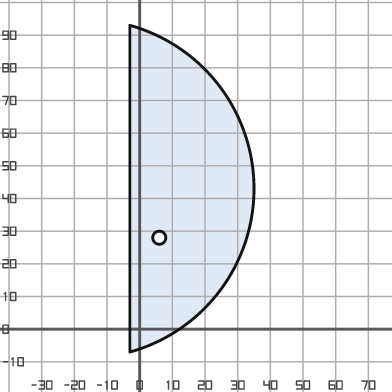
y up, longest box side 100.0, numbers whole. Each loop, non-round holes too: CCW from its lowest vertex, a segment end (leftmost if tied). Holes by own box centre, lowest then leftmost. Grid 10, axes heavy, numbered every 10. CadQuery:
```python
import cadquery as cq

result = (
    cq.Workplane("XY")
    .moveTo(-3.0, -7.0)
    .threePointArc((35.0, 43.0), (-3.0, 93.0))
    .close()
    .moveTo(6.0, 28.0)
    .circle(2.0)
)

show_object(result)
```